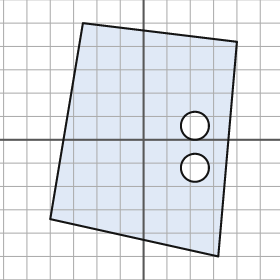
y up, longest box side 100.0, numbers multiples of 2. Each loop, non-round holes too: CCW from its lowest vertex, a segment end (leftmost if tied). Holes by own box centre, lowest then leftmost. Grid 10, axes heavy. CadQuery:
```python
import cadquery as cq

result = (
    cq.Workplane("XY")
    .moveTo(32.0, -50.0)
    .lineTo(40.0, 42.0)
    .lineTo(-26.0, 50.0)
    .lineTo(-40.0, -34.0)
    .close()
    .moveTo(22.0, -12.0)
    .circle(6.0)
    .moveTo(22.0, 6.0)
    .circle(6.0)
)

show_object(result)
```